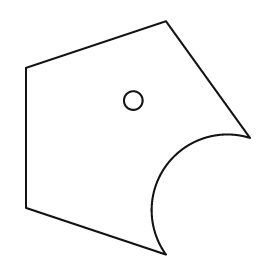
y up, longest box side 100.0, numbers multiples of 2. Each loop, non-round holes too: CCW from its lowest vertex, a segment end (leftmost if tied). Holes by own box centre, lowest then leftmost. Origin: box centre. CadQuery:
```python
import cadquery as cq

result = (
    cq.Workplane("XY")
    .moveTo(12.0, -50.0)
    .threePointArc((12.0, -12.0), (48.0, 0.0))
    .lineTo(12.0, 50.0)
    .lineTo(-48.0, 30.0)
    .lineTo(-48.0, -30.0)
    .close()
    .moveTo(-2.0, 16.0)
    .circle(4.0)
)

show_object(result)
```